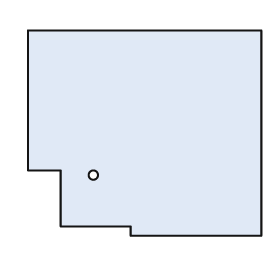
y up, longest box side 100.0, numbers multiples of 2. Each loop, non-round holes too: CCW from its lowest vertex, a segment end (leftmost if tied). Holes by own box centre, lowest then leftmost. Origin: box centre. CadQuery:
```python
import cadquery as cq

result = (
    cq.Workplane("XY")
    .moveTo(-6.0, -44.0)
    .lineTo(50.0, -44.0)
    .lineTo(50.0, 44.0)
    .lineTo(-50.0, 44.0)
    .lineTo(-50.0, -16.0)
    .lineTo(-36.0, -16.0)
    .lineTo(-36.0, -40.0)
    .lineTo(-6.0, -40.0)
    .close()
    .moveTo(-22.0, -18.0)
    .circle(2.0)
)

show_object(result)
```